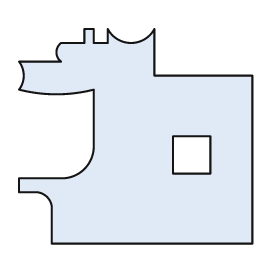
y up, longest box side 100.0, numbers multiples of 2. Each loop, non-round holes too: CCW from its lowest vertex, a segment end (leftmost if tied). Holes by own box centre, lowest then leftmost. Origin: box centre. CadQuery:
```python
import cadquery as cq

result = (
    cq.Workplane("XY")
    .moveTo(-36.0, -46.0)
    .lineTo(50.0, -46.0)
    .lineTo(50.0, 26.0)
    .lineTo(8.0, 26.0)
    .lineTo(8.0, 46.0)
    .threePointArc((-2.0, 40.0), (-12.0, 46.0))
    .lineTo(-12.0, 40.0)
    .lineTo(-18.0, 40.0)
    .lineTo(-18.0, 46.0)
    .lineTo(-22.0, 46.0)
    .lineTo(-22.0, 40.0)
    .lineTo(-32.0, 40.0)
    .threePointArc((-34.0, 36.0), (-32.0, 32.0))
    .lineTo(-50.0, 32.0)
    .threePointArc((-48.0, 26.0), (-50.0, 20.0))
    .threePointArc((-34.0, 18.0), (-18.0, 20.0))
    .lineTo(-18.0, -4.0)
    .threePointArc((-22.0, -14.0), (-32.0, -18.0))
    .lineTo(-50.0, -18.0)
    .lineTo(-50.0, -24.0)
    .lineTo(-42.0, -24.0)
    .threePointArc((-38.0, -26.0), (-36.0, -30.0))
    .close()
    .moveTo(16.0, -16.0)
    .lineTo(32.0, -16.0)
    .lineTo(32.0, 0.0)
    .lineTo(16.0, 0.0)
    .close()
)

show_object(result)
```